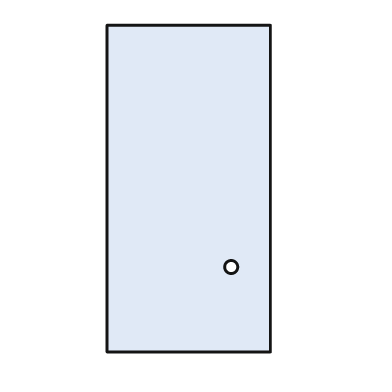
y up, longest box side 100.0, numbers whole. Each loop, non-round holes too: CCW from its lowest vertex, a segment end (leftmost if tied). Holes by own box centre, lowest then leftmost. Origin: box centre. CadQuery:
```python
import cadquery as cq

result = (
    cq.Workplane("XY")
    .moveTo(-25.0, -50.0)
    .lineTo(25.0, -50.0)
    .lineTo(25.0, 50.0)
    .lineTo(-25.0, 50.0)
    .close()
    .moveTo(13.0, -24.0)
    .circle(2.0)
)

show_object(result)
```